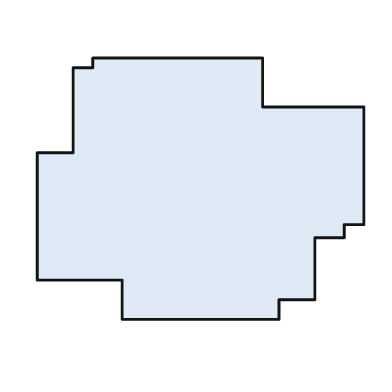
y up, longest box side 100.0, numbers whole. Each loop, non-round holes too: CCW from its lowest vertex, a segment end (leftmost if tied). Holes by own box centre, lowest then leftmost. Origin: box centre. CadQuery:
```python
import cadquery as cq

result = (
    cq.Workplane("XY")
    .moveTo(-24.0, -40.0)
    .lineTo(24.0, -40.0)
    .lineTo(24.0, -34.0)
    .lineTo(35.0, -34.0)
    .lineTo(35.0, -15.0)
    .lineTo(44.0, -15.0)
    .lineTo(44.0, -11.0)
    .lineTo(50.0, -11.0)
    .lineTo(50.0, 25.0)
    .lineTo(19.0, 25.0)
    .lineTo(19.0, 40.0)
    .lineTo(-33.0, 40.0)
    .lineTo(-33.0, 37.0)
    .lineTo(-39.0, 37.0)
    .lineTo(-39.0, 11.0)
    .lineTo(-50.0, 11.0)
    .lineTo(-50.0, -28.0)
    .lineTo(-24.0, -28.0)
    .close()
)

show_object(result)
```